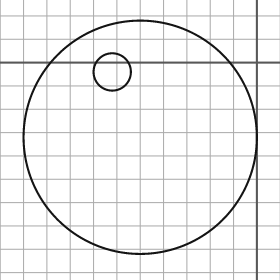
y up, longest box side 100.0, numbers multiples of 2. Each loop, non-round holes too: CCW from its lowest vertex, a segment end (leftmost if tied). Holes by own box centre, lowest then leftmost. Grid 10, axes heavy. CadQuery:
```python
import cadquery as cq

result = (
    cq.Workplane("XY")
    .moveTo(-50.0, -32.0)
    .circle(50.0)
    .moveTo(-62.0, -4.0)
    .circle(8.0)
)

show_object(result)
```